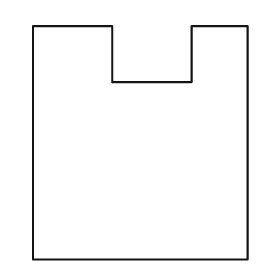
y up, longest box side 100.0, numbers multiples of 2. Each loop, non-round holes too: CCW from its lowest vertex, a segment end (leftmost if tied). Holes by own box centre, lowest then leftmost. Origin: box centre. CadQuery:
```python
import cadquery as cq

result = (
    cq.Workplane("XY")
    .moveTo(-46.0, -50.0)
    .lineTo(46.0, -50.0)
    .lineTo(46.0, 50.0)
    .lineTo(22.0, 50.0)
    .lineTo(22.0, 26.0)
    .lineTo(-12.0, 26.0)
    .lineTo(-12.0, 50.0)
    .lineTo(-46.0, 50.0)
    .close()
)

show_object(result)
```